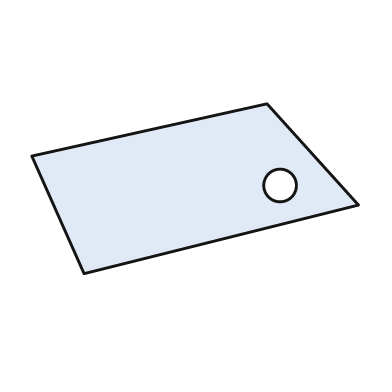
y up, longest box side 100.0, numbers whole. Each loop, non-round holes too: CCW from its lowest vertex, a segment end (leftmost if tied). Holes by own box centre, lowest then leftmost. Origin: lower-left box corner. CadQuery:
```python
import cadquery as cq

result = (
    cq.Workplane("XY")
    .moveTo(16.0, 0.0)
    .lineTo(100.0, 21.0)
    .lineTo(72.0, 52.0)
    .lineTo(0.0, 36.0)
    .close()
    .moveTo(76.0, 27.0)
    .circle(5.0)
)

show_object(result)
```